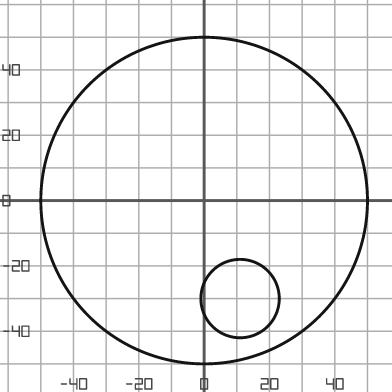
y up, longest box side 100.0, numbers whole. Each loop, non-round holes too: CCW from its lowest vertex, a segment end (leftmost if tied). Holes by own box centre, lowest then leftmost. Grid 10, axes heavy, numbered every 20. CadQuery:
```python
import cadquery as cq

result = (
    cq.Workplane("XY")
    .moveTo(0.0, 0.0)
    .circle(50.0)
    .moveTo(11.0, -30.0)
    .circle(12.0)
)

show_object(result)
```